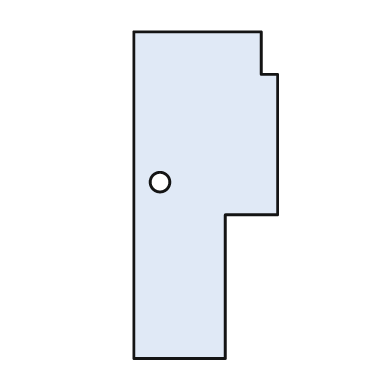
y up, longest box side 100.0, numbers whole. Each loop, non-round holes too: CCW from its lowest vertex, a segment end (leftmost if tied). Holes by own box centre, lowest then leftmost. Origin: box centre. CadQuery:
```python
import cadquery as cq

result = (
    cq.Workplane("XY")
    .moveTo(-22.0, -50.0)
    .lineTo(6.0, -50.0)
    .lineTo(6.0, -6.0)
    .lineTo(22.0, -6.0)
    .lineTo(22.0, 37.0)
    .lineTo(17.0, 37.0)
    .lineTo(17.0, 50.0)
    .lineTo(-22.0, 50.0)
    .close()
    .moveTo(-14.0, 4.0)
    .circle(3.0)
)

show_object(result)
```